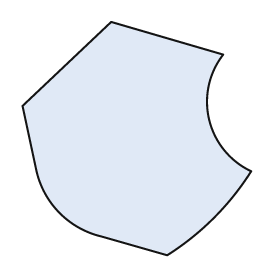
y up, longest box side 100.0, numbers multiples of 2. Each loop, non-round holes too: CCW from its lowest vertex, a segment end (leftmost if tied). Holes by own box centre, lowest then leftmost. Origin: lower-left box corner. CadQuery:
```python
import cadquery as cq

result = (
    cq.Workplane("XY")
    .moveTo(62.0, 0.0)
    .threePointArc((82.0, 16.0), (98.0, 36.0))
    .threePointArc((80.0, 58.0), (86.0, 86.0))
    .lineTo(38.0, 100.0)
    .lineTo(0.0, 64.0)
    .lineTo(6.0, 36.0)
    .threePointArc((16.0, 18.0), (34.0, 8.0))
    .close()
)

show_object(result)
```